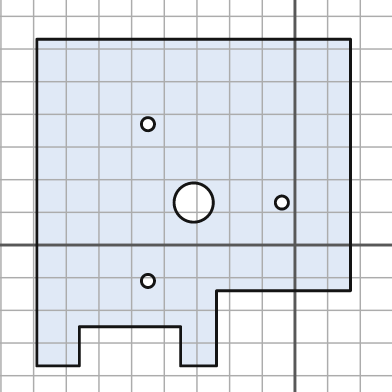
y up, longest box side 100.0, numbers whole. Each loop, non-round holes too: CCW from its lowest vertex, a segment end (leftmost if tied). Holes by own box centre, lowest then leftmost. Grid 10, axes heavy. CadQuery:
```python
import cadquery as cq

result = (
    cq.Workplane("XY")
    .moveTo(-79.0, -37.0)
    .lineTo(-66.0, -37.0)
    .lineTo(-66.0, -25.0)
    .lineTo(-35.0, -25.0)
    .lineTo(-35.0, -37.0)
    .lineTo(-24.0, -37.0)
    .lineTo(-24.0, -14.0)
    .lineTo(17.0, -14.0)
    .lineTo(17.0, 63.0)
    .lineTo(-79.0, 63.0)
    .close()
    .moveTo(-45.0, -11.0)
    .circle(2.0)
    .moveTo(-31.0, 13.0)
    .circle(6.0)
    .moveTo(-4.0, 13.0)
    .circle(2.0)
    .moveTo(-45.0, 37.0)
    .circle(2.0)
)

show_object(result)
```